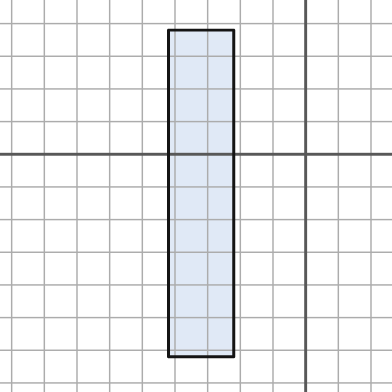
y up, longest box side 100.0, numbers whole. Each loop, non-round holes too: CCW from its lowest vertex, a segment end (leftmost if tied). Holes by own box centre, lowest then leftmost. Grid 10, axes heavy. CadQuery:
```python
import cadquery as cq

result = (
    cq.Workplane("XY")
    .moveTo(-42.0, -62.0)
    .lineTo(-22.0, -62.0)
    .lineTo(-22.0, 38.0)
    .lineTo(-42.0, 38.0)
    .close()
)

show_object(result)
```